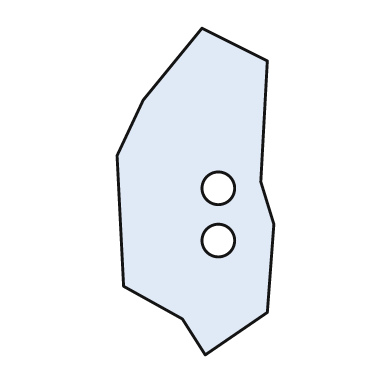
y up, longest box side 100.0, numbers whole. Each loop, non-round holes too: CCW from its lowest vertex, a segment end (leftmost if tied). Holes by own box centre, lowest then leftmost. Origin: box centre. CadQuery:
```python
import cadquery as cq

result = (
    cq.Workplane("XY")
    .moveTo(3.0, -50.0)
    .lineTo(22.0, -37.0)
    .lineTo(24.0, -10.0)
    .lineTo(20.0, 3.0)
    .lineTo(22.0, 40.0)
    .lineTo(2.0, 50.0)
    .lineTo(-16.0, 28.0)
    .lineTo(-24.0, 11.0)
    .lineTo(-22.0, -29.0)
    .lineTo(-4.0, -39.0)
    .close()
    .moveTo(7.0, -15.0)
    .circle(5.0)
    .moveTo(7.0, 1.0)
    .circle(5.0)
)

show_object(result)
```